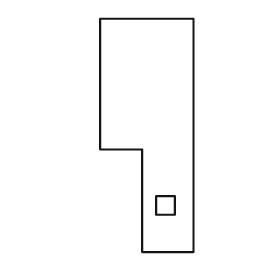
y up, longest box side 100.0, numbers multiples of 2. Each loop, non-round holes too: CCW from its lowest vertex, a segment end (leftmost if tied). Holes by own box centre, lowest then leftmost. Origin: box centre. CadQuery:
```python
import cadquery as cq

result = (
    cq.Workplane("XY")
    .moveTo(-2.0, -50.0)
    .lineTo(20.0, -50.0)
    .lineTo(20.0, 50.0)
    .lineTo(-20.0, 50.0)
    .lineTo(-20.0, -6.0)
    .lineTo(-2.0, -6.0)
    .close()
    .moveTo(4.0, -34.0)
    .lineTo(12.0, -34.0)
    .lineTo(12.0, -26.0)
    .lineTo(4.0, -26.0)
    .close()
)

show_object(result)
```